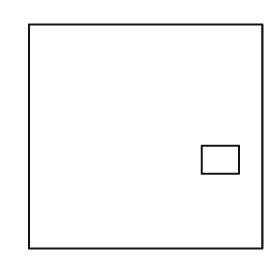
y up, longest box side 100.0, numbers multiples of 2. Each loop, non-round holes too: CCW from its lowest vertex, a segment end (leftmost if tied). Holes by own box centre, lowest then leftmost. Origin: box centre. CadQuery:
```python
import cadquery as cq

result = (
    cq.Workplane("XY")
    .moveTo(-50.0, -48.0)
    .lineTo(50.0, -48.0)
    .lineTo(50.0, 48.0)
    .lineTo(-50.0, 48.0)
    .close()
    .moveTo(24.0, -16.0)
    .lineTo(40.0, -16.0)
    .lineTo(40.0, -4.0)
    .lineTo(24.0, -4.0)
    .close()
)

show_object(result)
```